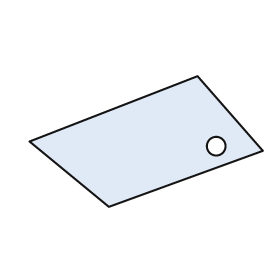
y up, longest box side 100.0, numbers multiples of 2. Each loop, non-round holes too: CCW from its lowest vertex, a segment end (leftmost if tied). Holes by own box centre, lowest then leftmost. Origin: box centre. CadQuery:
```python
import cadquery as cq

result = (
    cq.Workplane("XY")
    .moveTo(-16.0, -28.0)
    .lineTo(50.0, -4.0)
    .lineTo(22.0, 28.0)
    .lineTo(-50.0, 0.0)
    .close()
    .moveTo(30.0, -2.0)
    .circle(4.0)
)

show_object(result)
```